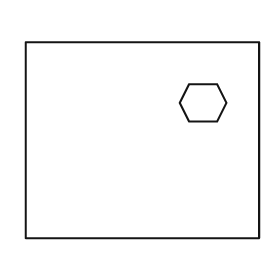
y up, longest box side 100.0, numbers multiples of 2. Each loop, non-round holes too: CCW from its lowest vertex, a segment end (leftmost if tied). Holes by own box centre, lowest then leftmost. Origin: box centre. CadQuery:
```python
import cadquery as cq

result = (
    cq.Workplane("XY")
    .moveTo(-50.0, -42.0)
    .lineTo(50.0, -42.0)
    .lineTo(50.0, 42.0)
    .lineTo(-50.0, 42.0)
    .close()
    .moveTo(20.0, 8.0)
    .lineTo(32.0, 8.0)
    .lineTo(36.0, 16.0)
    .lineTo(32.0, 24.0)
    .lineTo(20.0, 24.0)
    .lineTo(16.0, 16.0)
    .close()
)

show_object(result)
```